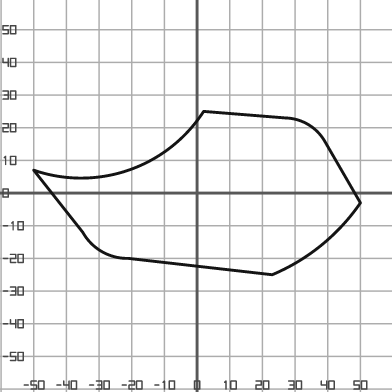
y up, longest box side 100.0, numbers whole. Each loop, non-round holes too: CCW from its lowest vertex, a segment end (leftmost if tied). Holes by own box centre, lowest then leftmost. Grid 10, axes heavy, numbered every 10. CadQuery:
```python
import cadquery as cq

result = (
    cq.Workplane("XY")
    .moveTo(23.0, -25.0)
    .threePointArc((38.0, -16.0), (50.0, -3.0))
    .lineTo(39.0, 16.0)
    .threePointArc((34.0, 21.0), (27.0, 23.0))
    .lineTo(2.0, 25.0)
    .threePointArc((-21.0, 7.0), (-50.0, 7.0))
    .lineTo(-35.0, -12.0)
    .threePointArc((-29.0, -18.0), (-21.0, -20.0))
    .close()
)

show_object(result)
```